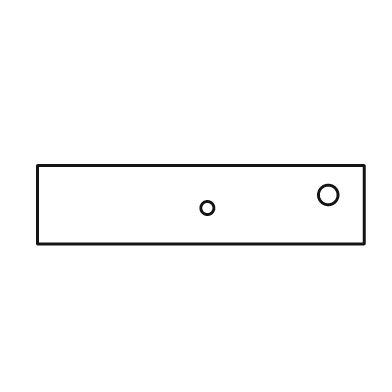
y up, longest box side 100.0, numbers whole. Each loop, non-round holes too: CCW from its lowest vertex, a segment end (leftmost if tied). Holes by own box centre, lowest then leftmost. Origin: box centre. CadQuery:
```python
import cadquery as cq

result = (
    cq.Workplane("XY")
    .moveTo(-50.0, -12.0)
    .lineTo(50.0, -12.0)
    .lineTo(50.0, 12.0)
    .lineTo(-50.0, 12.0)
    .close()
    .moveTo(2.0, -1.0)
    .circle(2.0)
    .moveTo(39.0, 3.0)
    .circle(3.0)
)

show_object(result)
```